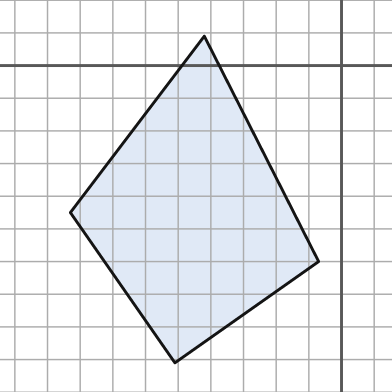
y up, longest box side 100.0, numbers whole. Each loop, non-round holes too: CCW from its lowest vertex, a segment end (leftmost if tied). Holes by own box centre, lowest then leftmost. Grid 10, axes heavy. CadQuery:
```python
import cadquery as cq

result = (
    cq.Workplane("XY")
    .moveTo(-51.0, -91.0)
    .lineTo(-7.0, -60.0)
    .lineTo(-42.0, 9.0)
    .lineTo(-83.0, -45.0)
    .close()
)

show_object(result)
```